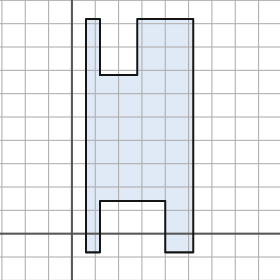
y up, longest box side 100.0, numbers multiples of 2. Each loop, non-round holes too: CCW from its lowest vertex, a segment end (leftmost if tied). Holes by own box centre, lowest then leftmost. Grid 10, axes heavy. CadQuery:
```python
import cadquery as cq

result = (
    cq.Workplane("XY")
    .moveTo(6.0, -8.0)
    .lineTo(12.0, -8.0)
    .lineTo(12.0, 14.0)
    .lineTo(40.0, 14.0)
    .lineTo(40.0, -8.0)
    .lineTo(52.0, -8.0)
    .lineTo(52.0, 92.0)
    .lineTo(28.0, 92.0)
    .lineTo(28.0, 68.0)
    .lineTo(12.0, 68.0)
    .lineTo(12.0, 92.0)
    .lineTo(6.0, 92.0)
    .close()
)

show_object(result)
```